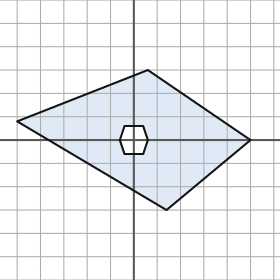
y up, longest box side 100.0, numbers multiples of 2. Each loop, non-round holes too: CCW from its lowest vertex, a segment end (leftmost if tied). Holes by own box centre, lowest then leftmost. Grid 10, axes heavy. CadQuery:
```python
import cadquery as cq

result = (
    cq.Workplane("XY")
    .moveTo(14.0, -30.0)
    .lineTo(50.0, 0.0)
    .lineTo(6.0, 30.0)
    .lineTo(-50.0, 8.0)
    .close()
    .moveTo(-4.0, -6.0)
    .lineTo(4.0, -6.0)
    .lineTo(6.0, 0.0)
    .lineTo(4.0, 6.0)
    .lineTo(-4.0, 6.0)
    .lineTo(-6.0, 0.0)
    .close()
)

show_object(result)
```